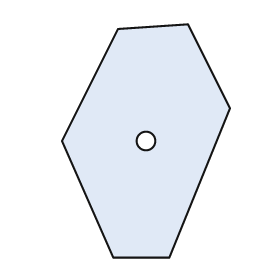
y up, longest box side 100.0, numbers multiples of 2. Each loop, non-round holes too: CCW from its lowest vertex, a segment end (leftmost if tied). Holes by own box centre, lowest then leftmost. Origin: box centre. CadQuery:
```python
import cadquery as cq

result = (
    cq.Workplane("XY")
    .moveTo(-14.0, -50.0)
    .lineTo(10.0, -50.0)
    .lineTo(36.0, 14.0)
    .lineTo(18.0, 50.0)
    .lineTo(-12.0, 48.0)
    .lineTo(-36.0, 0.0)
    .close()
    .moveTo(0.0, 0.0)
    .circle(4.0)
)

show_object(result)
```